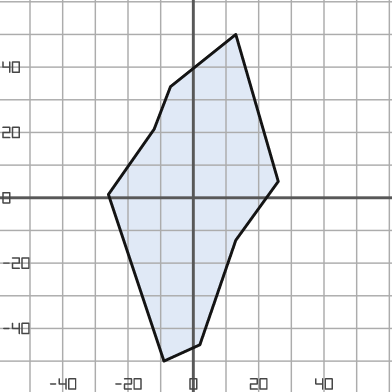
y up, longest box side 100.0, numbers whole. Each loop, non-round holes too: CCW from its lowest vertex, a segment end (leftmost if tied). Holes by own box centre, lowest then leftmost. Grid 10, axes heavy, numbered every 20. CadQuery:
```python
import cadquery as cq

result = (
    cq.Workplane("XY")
    .moveTo(-9.0, -50.0)
    .lineTo(2.0, -45.0)
    .lineTo(13.0, -13.0)
    .lineTo(26.0, 5.0)
    .lineTo(13.0, 50.0)
    .lineTo(-7.0, 34.0)
    .lineTo(-12.0, 21.0)
    .lineTo(-26.0, 1.0)
    .close()
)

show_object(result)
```